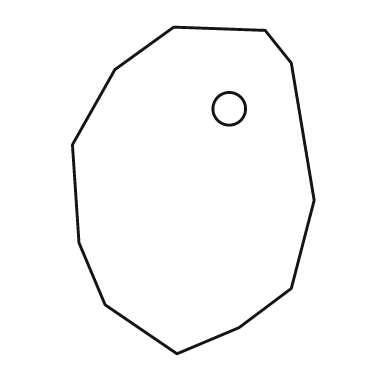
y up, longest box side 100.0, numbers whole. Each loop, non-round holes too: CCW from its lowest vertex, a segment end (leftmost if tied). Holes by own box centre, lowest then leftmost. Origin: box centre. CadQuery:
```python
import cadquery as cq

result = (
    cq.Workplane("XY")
    .moveTo(-5.0, -50.0)
    .lineTo(14.0, -42.0)
    .lineTo(30.0, -30.0)
    .lineTo(37.0, -3.0)
    .lineTo(30.0, 39.0)
    .lineTo(22.0, 49.0)
    .lineTo(-6.0, 50.0)
    .lineTo(-24.0, 37.0)
    .lineTo(-37.0, 14.0)
    .lineTo(-35.0, -16.0)
    .lineTo(-27.0, -35.0)
    .close()
    .moveTo(11.0, 25.0)
    .circle(5.0)
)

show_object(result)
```